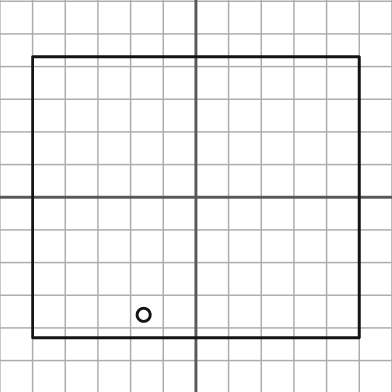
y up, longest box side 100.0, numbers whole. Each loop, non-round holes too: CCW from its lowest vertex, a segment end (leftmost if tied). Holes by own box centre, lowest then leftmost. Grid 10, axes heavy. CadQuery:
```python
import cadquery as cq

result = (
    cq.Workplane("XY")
    .moveTo(-50.0, -43.0)
    .lineTo(50.0, -43.0)
    .lineTo(50.0, 43.0)
    .lineTo(-50.0, 43.0)
    .close()
    .moveTo(-16.0, -36.0)
    .circle(2.0)
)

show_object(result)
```